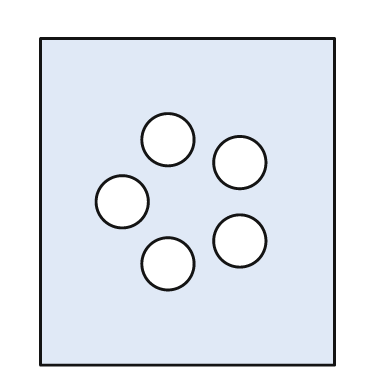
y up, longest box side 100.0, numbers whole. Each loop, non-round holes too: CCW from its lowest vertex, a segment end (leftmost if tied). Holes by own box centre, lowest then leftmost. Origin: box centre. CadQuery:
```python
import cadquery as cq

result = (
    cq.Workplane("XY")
    .moveTo(-45.0, -50.0)
    .lineTo(45.0, -50.0)
    .lineTo(45.0, 50.0)
    .lineTo(-45.0, 50.0)
    .close()
    .moveTo(-6.0, -19.0)
    .circle(8.0)
    .moveTo(16.0, -12.0)
    .circle(8.0)
    .moveTo(-20.0, 0.0)
    .circle(8.0)
    .moveTo(16.0, 12.0)
    .circle(8.0)
    .moveTo(-6.0, 19.0)
    .circle(8.0)
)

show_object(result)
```